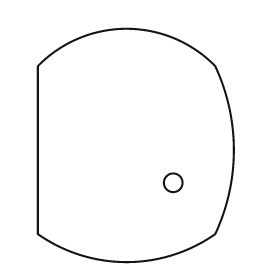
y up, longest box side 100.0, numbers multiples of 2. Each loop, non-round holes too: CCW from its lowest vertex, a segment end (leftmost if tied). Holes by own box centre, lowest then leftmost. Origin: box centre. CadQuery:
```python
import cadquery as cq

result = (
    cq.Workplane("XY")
    .moveTo(-42.0, -38.0)
    .threePointArc((-4.0, -50.0), (34.0, -38.0))
    .threePointArc((42.0, -2.0), (34.0, 34.0))
    .threePointArc((-4.0, 50.0), (-42.0, 34.0))
    .close()
    .moveTo(16.0, -16.0)
    .circle(4.0)
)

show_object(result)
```